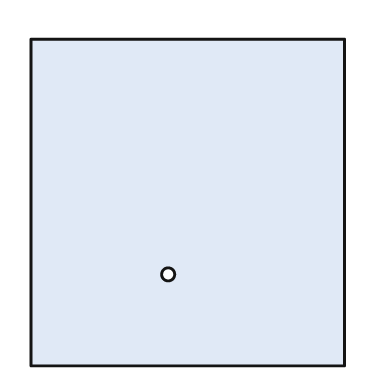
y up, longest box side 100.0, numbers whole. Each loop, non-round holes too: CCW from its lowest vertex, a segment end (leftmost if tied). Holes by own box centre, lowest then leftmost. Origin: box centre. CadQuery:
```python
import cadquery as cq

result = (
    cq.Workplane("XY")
    .moveTo(-48.0, -50.0)
    .lineTo(48.0, -50.0)
    .lineTo(48.0, 50.0)
    .lineTo(-48.0, 50.0)
    .close()
    .moveTo(-6.0, -22.0)
    .circle(2.0)
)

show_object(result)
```